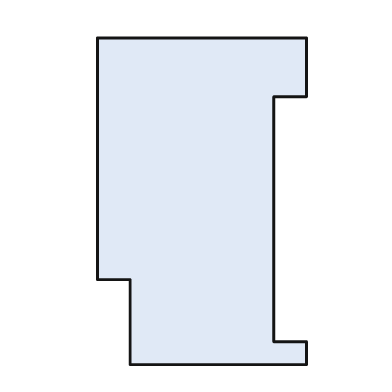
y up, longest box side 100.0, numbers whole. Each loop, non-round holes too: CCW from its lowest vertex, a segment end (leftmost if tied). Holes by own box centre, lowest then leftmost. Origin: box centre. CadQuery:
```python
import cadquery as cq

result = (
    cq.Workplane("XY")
    .moveTo(-22.0, -50.0)
    .lineTo(32.0, -50.0)
    .lineTo(32.0, -43.0)
    .lineTo(22.0, -43.0)
    .lineTo(22.0, 32.0)
    .lineTo(32.0, 32.0)
    .lineTo(32.0, 50.0)
    .lineTo(-32.0, 50.0)
    .lineTo(-32.0, -24.0)
    .lineTo(-22.0, -24.0)
    .close()
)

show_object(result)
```